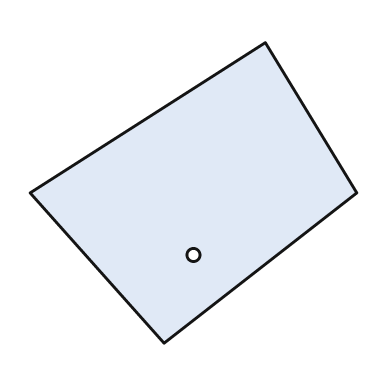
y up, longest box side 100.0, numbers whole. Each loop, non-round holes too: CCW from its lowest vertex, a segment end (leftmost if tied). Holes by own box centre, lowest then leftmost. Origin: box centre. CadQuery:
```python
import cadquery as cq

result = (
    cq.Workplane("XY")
    .moveTo(-9.0, -46.0)
    .lineTo(50.0, 0.0)
    .lineTo(22.0, 46.0)
    .lineTo(-50.0, 0.0)
    .close()
    .moveTo(0.0, -19.0)
    .circle(2.0)
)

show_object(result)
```